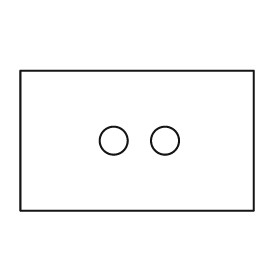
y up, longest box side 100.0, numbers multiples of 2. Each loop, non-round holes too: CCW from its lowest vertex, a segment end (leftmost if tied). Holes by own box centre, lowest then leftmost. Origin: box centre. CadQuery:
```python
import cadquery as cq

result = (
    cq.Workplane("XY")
    .moveTo(-50.0, -30.0)
    .lineTo(50.0, -30.0)
    .lineTo(50.0, 30.0)
    .lineTo(-50.0, 30.0)
    .close()
    .moveTo(-10.0, 0.0)
    .circle(6.0)
    .moveTo(12.0, 0.0)
    .circle(6.0)
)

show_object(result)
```